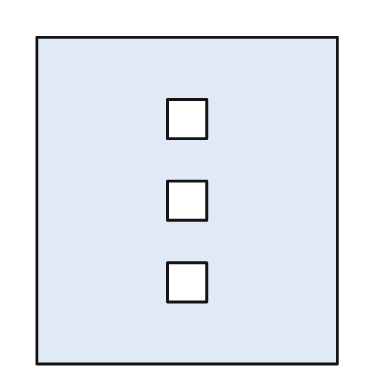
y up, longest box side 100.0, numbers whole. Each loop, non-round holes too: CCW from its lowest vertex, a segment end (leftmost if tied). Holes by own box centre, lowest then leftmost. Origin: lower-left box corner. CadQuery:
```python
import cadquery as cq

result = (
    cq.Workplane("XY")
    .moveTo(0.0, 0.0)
    .lineTo(92.0, 0.0)
    .lineTo(92.0, 100.0)
    .lineTo(0.0, 100.0)
    .close()
    .moveTo(40.0, 19.0)
    .lineTo(52.0, 19.0)
    .lineTo(52.0, 31.0)
    .lineTo(40.0, 31.0)
    .close()
    .moveTo(40.0, 44.0)
    .lineTo(52.0, 44.0)
    .lineTo(52.0, 56.0)
    .lineTo(40.0, 56.0)
    .close()
    .moveTo(40.0, 69.0)
    .lineTo(52.0, 69.0)
    .lineTo(52.0, 81.0)
    .lineTo(40.0, 81.0)
    .close()
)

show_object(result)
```